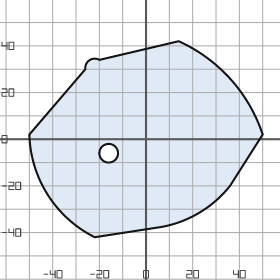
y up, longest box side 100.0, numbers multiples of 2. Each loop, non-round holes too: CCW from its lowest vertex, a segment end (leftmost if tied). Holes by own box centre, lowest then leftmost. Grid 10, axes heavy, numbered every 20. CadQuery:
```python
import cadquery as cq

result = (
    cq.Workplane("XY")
    .moveTo(-22.0, -42.0)
    .lineTo(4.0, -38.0)
    .threePointArc((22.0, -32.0), (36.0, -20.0))
    .lineTo(50.0, 2.0)
    .threePointArc((36.0, 26.0), (14.0, 42.0))
    .lineTo(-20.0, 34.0)
    .threePointArc((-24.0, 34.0), (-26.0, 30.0))
    .lineTo(-50.0, 2.0)
    .threePointArc((-42.0, -24.0), (-22.0, -42.0))
    .close()
    .moveTo(-16.0, -6.0)
    .circle(4.0)
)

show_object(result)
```